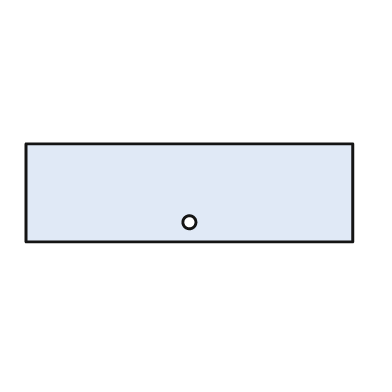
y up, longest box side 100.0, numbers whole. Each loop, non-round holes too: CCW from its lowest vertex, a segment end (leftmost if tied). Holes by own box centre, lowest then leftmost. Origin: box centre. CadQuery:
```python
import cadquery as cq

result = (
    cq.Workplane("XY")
    .moveTo(-50.0, -15.0)
    .lineTo(50.0, -15.0)
    .lineTo(50.0, 15.0)
    .lineTo(-50.0, 15.0)
    .close()
    .moveTo(0.0, -9.0)
    .circle(2.0)
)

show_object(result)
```